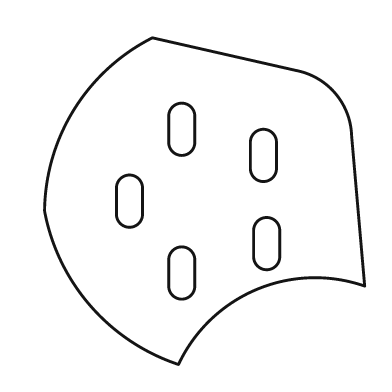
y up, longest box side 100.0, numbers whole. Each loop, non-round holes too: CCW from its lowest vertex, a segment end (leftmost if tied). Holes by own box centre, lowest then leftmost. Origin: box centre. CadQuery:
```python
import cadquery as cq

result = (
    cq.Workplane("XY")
    .moveTo(-8.0, -50.0)
    .threePointArc((16.0, -27.0), (49.0, -26.0))
    .lineTo(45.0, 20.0)
    .threePointArc((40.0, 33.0), (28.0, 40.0))
    .lineTo(-16.0, 50.0)
    .threePointArc((-40.0, 28.0), (-49.0, -3.0))
    .threePointArc((-35.0, -32.0), (-8.0, -50.0))
    .close()
    .moveTo(-11.0, -26.0)
    .threePointArc((-7.0, -30.0), (-3.0, -26.0))
    .lineTo(-3.0, -18.0)
    .threePointArc((-7.0, -14.0), (-11.0, -18.0))
    .close()
    .moveTo(15.0, -17.0)
    .threePointArc((19.0, -21.0), (23.0, -17.0))
    .lineTo(23.0, -9.0)
    .threePointArc((19.0, -5.0), (15.0, -9.0))
    .close()
    .moveTo(-27.0, -4.0)
    .threePointArc((-23.0, -8.0), (-19.0, -4.0))
    .lineTo(-19.0, 4.0)
    .threePointArc((-23.0, 8.0), (-27.0, 4.0))
    .close()
    .moveTo(14.0, 10.0)
    .threePointArc((18.0, 6.0), (22.0, 10.0))
    .lineTo(22.0, 18.0)
    .threePointArc((18.0, 22.0), (14.0, 18.0))
    .close()
    .moveTo(-11.0, 18.0)
    .threePointArc((-7.0, 14.0), (-3.0, 18.0))
    .lineTo(-3.0, 26.0)
    .threePointArc((-7.0, 30.0), (-11.0, 26.0))
    .close()
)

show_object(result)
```